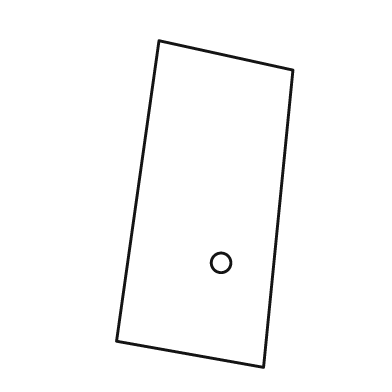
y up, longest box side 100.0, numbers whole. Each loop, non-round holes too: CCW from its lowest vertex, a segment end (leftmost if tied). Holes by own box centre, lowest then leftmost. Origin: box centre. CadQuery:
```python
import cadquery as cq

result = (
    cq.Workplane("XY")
    .moveTo(18.0, -50.0)
    .lineTo(27.0, 41.0)
    .lineTo(-14.0, 50.0)
    .lineTo(-27.0, -42.0)
    .close()
    .moveTo(5.0, -18.0)
    .circle(3.0)
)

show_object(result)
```